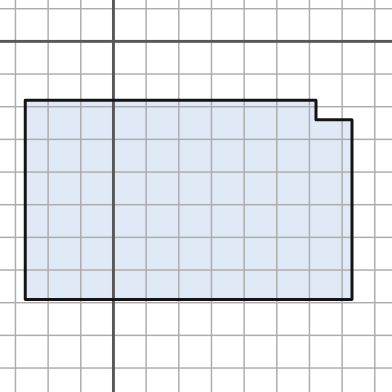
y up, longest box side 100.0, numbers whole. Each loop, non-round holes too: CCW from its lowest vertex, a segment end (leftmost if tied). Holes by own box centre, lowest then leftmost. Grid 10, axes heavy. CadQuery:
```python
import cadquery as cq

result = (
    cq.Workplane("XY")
    .moveTo(-27.0, -79.0)
    .lineTo(73.0, -79.0)
    .lineTo(73.0, -24.0)
    .lineTo(62.0, -24.0)
    .lineTo(62.0, -18.0)
    .lineTo(-27.0, -18.0)
    .close()
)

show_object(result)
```